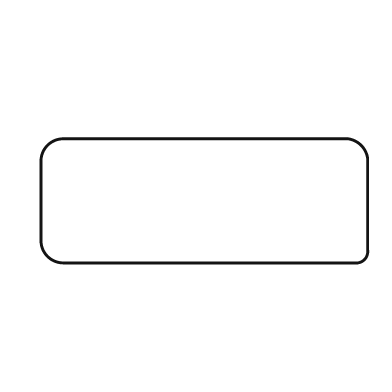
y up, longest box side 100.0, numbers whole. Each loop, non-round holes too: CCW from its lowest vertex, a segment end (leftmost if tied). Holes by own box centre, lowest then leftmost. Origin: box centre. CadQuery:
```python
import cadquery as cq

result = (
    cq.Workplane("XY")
    .moveTo(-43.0, -19.0)
    .lineTo(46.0, -19.0)
    .threePointArc((49.0, -18.0), (50.0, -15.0))
    .lineTo(50.0, 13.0)
    .threePointArc((48.0, 17.0), (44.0, 19.0))
    .lineTo(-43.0, 19.0)
    .threePointArc((-48.0, 17.0), (-50.0, 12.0))
    .lineTo(-50.0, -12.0)
    .threePointArc((-48.0, -17.0), (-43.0, -19.0))
    .close()
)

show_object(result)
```